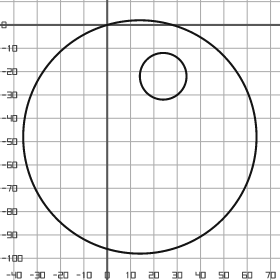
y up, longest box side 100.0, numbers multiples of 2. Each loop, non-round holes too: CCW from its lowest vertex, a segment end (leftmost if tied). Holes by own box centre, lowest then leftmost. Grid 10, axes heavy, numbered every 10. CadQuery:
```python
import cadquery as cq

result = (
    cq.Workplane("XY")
    .moveTo(14.0, -48.0)
    .circle(50.0)
    .moveTo(24.0, -22.0)
    .circle(10.0)
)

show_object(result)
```